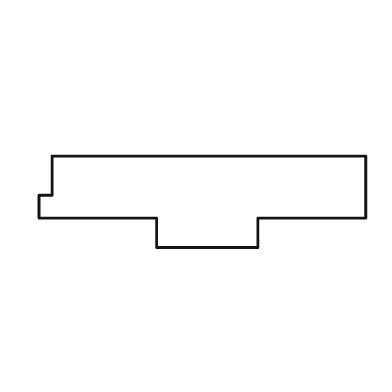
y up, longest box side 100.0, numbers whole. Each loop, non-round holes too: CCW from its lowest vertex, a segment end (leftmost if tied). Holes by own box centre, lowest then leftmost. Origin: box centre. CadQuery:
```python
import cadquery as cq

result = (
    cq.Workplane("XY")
    .moveTo(-14.0, -14.0)
    .lineTo(17.0, -14.0)
    .lineTo(17.0, -5.0)
    .lineTo(50.0, -5.0)
    .lineTo(50.0, 14.0)
    .lineTo(-46.0, 14.0)
    .lineTo(-46.0, 2.0)
    .lineTo(-50.0, 2.0)
    .lineTo(-50.0, -5.0)
    .lineTo(-14.0, -5.0)
    .close()
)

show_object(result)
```